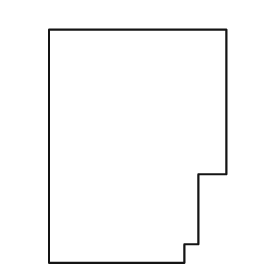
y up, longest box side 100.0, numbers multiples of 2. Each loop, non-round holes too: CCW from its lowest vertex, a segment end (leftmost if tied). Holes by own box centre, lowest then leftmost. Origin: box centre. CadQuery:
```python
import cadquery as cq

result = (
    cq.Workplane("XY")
    .moveTo(-38.0, -50.0)
    .lineTo(20.0, -50.0)
    .lineTo(20.0, -42.0)
    .lineTo(26.0, -42.0)
    .lineTo(26.0, -12.0)
    .lineTo(38.0, -12.0)
    .lineTo(38.0, 50.0)
    .lineTo(-38.0, 50.0)
    .close()
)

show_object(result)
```